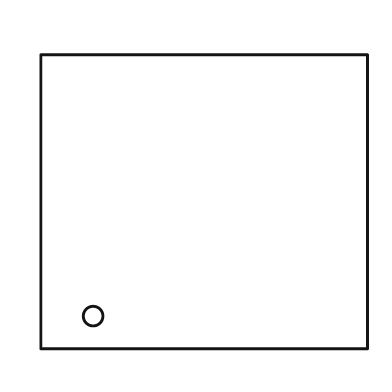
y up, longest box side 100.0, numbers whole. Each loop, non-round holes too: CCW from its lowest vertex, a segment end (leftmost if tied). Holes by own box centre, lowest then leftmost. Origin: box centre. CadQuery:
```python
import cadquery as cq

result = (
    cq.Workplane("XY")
    .moveTo(-50.0, -45.0)
    .lineTo(50.0, -45.0)
    .lineTo(50.0, 45.0)
    .lineTo(-50.0, 45.0)
    .close()
    .moveTo(-34.0, -35.0)
    .circle(3.0)
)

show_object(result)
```